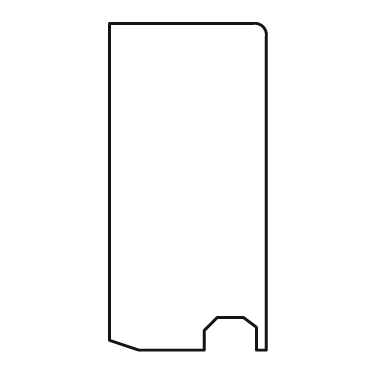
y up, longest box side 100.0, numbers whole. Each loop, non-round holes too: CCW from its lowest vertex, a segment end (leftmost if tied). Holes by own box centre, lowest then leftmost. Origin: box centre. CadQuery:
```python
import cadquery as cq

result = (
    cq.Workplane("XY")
    .moveTo(-15.0, -50.0)
    .lineTo(5.0, -50.0)
    .lineTo(5.0, -44.0)
    .lineTo(9.0, -40.0)
    .lineTo(17.0, -40.0)
    .lineTo(21.0, -43.0)
    .lineTo(21.0, -50.0)
    .lineTo(24.0, -50.0)
    .lineTo(24.0, 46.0)
    .threePointArc((23.0, 49.0), (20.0, 50.0))
    .lineTo(-24.0, 50.0)
    .lineTo(-24.0, -47.0)
    .close()
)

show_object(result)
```